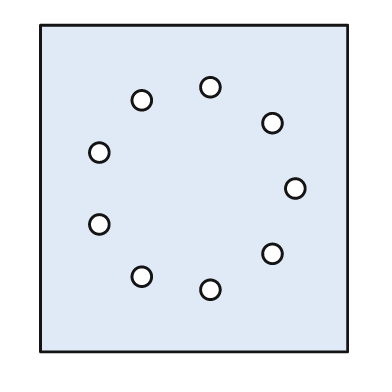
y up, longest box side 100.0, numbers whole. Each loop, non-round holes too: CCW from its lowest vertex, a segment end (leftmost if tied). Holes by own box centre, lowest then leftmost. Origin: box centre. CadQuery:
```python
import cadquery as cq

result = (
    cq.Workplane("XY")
    .moveTo(-47.0, -50.0)
    .lineTo(47.0, -50.0)
    .lineTo(47.0, 50.0)
    .lineTo(-47.0, 50.0)
    .close()
    .moveTo(5.0, -31.0)
    .circle(3.0)
    .moveTo(-16.0, -27.0)
    .circle(3.0)
    .moveTo(24.0, -20.0)
    .circle(3.0)
    .moveTo(-29.0, -11.0)
    .circle(3.0)
    .moveTo(31.0, 0.0)
    .circle(3.0)
    .moveTo(-29.0, 11.0)
    .circle(3.0)
    .moveTo(24.0, 20.0)
    .circle(3.0)
    .moveTo(-16.0, 27.0)
    .circle(3.0)
    .moveTo(5.0, 31.0)
    .circle(3.0)
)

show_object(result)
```